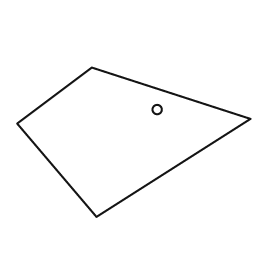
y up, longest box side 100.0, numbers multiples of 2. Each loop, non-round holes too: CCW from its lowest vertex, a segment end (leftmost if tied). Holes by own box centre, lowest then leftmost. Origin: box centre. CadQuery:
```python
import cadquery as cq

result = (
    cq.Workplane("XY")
    .moveTo(-16.0, -32.0)
    .lineTo(50.0, 10.0)
    .lineTo(-18.0, 32.0)
    .lineTo(-50.0, 8.0)
    .close()
    .moveTo(10.0, 14.0)
    .circle(2.0)
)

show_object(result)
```